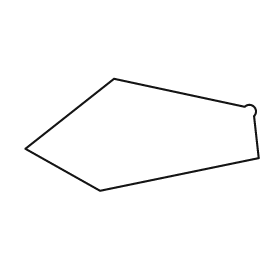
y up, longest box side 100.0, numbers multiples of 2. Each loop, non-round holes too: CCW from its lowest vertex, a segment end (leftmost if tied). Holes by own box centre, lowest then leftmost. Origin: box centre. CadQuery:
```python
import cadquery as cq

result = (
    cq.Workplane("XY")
    .moveTo(-18.0, -24.0)
    .lineTo(50.0, -10.0)
    .lineTo(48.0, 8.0)
    .threePointArc((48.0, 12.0), (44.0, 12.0))
    .lineTo(-12.0, 24.0)
    .lineTo(-50.0, -6.0)
    .close()
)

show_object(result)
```